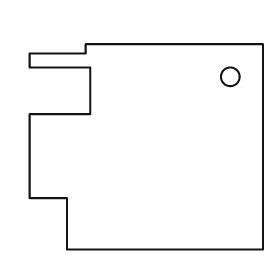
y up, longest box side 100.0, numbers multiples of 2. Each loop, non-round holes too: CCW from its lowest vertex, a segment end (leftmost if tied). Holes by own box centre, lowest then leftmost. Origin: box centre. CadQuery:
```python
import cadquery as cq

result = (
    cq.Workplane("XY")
    .moveTo(-34.0, -44.0)
    .lineTo(50.0, -44.0)
    .lineTo(50.0, 44.0)
    .lineTo(-26.0, 44.0)
    .lineTo(-26.0, 40.0)
    .lineTo(-50.0, 40.0)
    .lineTo(-50.0, 34.0)
    .lineTo(-24.0, 34.0)
    .lineTo(-24.0, 14.0)
    .lineTo(-50.0, 14.0)
    .lineTo(-50.0, -22.0)
    .lineTo(-34.0, -22.0)
    .close()
    .moveTo(36.0, 30.0)
    .circle(4.0)
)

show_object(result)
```